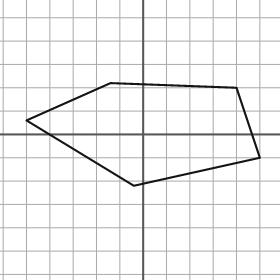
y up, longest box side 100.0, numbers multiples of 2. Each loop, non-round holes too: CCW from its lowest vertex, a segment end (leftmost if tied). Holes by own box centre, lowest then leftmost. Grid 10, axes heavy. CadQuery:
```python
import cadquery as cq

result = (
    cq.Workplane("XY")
    .moveTo(-4.0, -22.0)
    .lineTo(50.0, -10.0)
    .lineTo(40.0, 20.0)
    .lineTo(-14.0, 22.0)
    .lineTo(-50.0, 6.0)
    .close()
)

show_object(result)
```